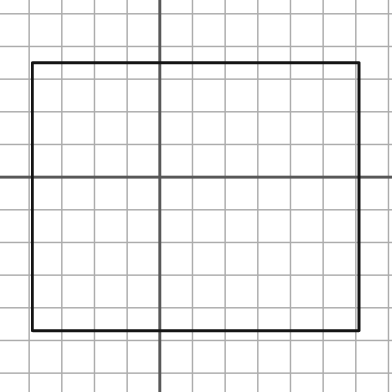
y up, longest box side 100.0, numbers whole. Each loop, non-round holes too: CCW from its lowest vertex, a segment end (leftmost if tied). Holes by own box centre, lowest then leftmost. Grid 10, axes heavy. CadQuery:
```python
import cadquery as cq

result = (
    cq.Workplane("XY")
    .moveTo(-39.0, -47.0)
    .lineTo(61.0, -47.0)
    .lineTo(61.0, 35.0)
    .lineTo(-39.0, 35.0)
    .close()
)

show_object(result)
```